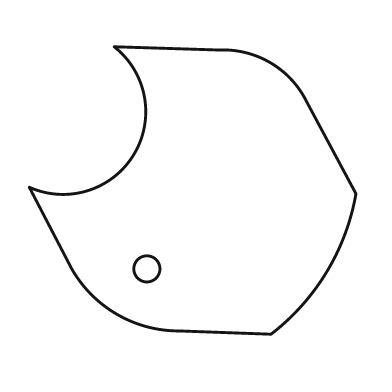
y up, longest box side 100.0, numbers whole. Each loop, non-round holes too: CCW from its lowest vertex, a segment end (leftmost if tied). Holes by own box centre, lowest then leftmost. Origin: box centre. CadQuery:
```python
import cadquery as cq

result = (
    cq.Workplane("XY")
    .moveTo(24.0, -44.0)
    .threePointArc((41.0, -25.0), (50.0, -1.0))
    .lineTo(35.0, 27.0)
    .threePointArc((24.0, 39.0), (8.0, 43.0))
    .lineTo(-24.0, 44.0)
    .threePointArc((-18.0, 11.0), (-50.0, 1.0))
    .lineTo(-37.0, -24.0)
    .threePointArc((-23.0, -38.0), (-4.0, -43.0))
    .close()
    .moveTo(-14.0, -24.0)
    .circle(4.0)
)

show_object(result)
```